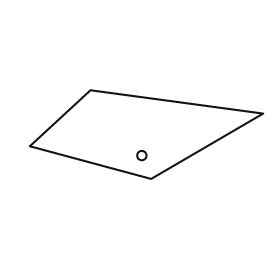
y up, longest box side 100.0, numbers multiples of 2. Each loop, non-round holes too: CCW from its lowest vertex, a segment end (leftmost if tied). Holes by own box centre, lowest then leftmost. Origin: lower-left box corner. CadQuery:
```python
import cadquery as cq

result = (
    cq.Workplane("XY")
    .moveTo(52.0, 0.0)
    .lineTo(100.0, 28.0)
    .lineTo(26.0, 38.0)
    .lineTo(0.0, 14.0)
    .close()
    .moveTo(48.0, 10.0)
    .circle(2.0)
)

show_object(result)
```